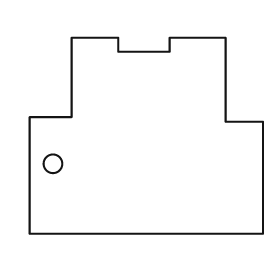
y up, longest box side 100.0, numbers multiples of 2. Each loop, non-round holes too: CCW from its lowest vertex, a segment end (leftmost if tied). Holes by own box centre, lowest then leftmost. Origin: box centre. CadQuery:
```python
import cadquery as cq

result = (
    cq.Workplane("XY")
    .moveTo(-50.0, -42.0)
    .lineTo(50.0, -42.0)
    .lineTo(50.0, 6.0)
    .lineTo(34.0, 6.0)
    .lineTo(34.0, 42.0)
    .lineTo(10.0, 42.0)
    .lineTo(10.0, 36.0)
    .lineTo(-12.0, 36.0)
    .lineTo(-12.0, 42.0)
    .lineTo(-32.0, 42.0)
    .lineTo(-32.0, 8.0)
    .lineTo(-50.0, 8.0)
    .close()
    .moveTo(-40.0, -12.0)
    .circle(4.0)
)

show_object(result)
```